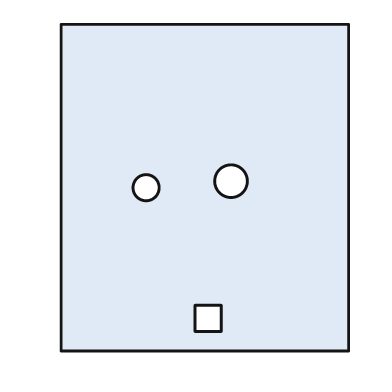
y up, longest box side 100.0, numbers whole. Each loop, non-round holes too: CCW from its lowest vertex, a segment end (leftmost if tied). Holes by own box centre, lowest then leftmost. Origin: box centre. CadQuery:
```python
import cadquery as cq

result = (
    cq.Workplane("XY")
    .moveTo(-44.0, -50.0)
    .lineTo(44.0, -50.0)
    .lineTo(44.0, 50.0)
    .lineTo(-44.0, 50.0)
    .close()
    .moveTo(-3.0, -44.0)
    .lineTo(5.0, -44.0)
    .lineTo(5.0, -36.0)
    .lineTo(-3.0, -36.0)
    .close()
    .moveTo(-18.0, 0.0)
    .circle(4.0)
    .moveTo(8.0, 2.0)
    .circle(5.0)
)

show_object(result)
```